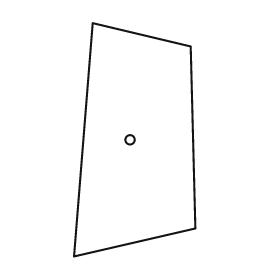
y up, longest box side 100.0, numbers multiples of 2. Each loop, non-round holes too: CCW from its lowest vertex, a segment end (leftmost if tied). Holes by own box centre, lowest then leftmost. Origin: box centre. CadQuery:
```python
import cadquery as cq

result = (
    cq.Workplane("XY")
    .moveTo(-26.0, -50.0)
    .lineTo(26.0, -38.0)
    .lineTo(24.0, 40.0)
    .lineTo(-18.0, 50.0)
    .close()
    .moveTo(-2.0, 0.0)
    .circle(2.0)
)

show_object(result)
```